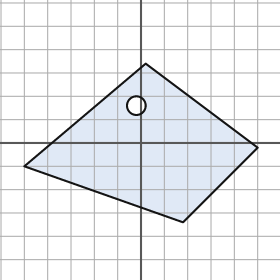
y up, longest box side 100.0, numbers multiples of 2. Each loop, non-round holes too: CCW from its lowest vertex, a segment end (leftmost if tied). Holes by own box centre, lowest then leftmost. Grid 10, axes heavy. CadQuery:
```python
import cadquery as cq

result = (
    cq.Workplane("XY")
    .moveTo(18.0, -34.0)
    .lineTo(50.0, -2.0)
    .lineTo(2.0, 34.0)
    .lineTo(-50.0, -10.0)
    .close()
    .moveTo(-2.0, 16.0)
    .circle(4.0)
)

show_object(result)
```